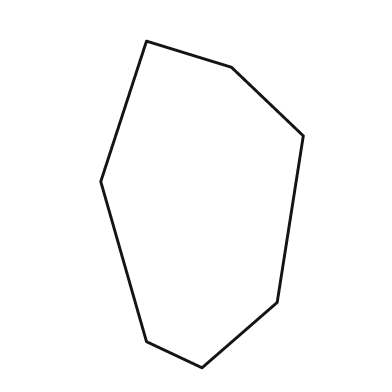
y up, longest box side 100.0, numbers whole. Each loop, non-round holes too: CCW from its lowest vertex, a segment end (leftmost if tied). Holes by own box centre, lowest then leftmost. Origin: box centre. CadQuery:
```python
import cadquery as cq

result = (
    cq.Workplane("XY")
    .moveTo(0.0, -50.0)
    .lineTo(23.0, -30.0)
    .lineTo(31.0, 21.0)
    .lineTo(9.0, 42.0)
    .lineTo(-17.0, 50.0)
    .lineTo(-31.0, 7.0)
    .lineTo(-17.0, -42.0)
    .close()
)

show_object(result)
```